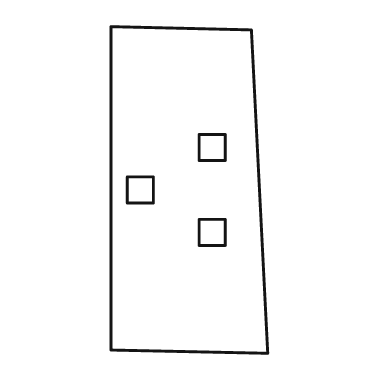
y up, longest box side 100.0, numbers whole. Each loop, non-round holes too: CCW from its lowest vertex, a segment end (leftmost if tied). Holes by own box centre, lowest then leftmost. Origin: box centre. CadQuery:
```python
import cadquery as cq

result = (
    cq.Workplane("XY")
    .moveTo(24.0, -50.0)
    .lineTo(19.0, 49.0)
    .lineTo(-24.0, 50.0)
    .lineTo(-24.0, -49.0)
    .close()
    .moveTo(3.0, -17.0)
    .lineTo(11.0, -17.0)
    .lineTo(11.0, -9.0)
    .lineTo(3.0, -9.0)
    .close()
    .moveTo(-19.0, -4.0)
    .lineTo(-11.0, -4.0)
    .lineTo(-11.0, 4.0)
    .lineTo(-19.0, 4.0)
    .close()
    .moveTo(3.0, 9.0)
    .lineTo(11.0, 9.0)
    .lineTo(11.0, 17.0)
    .lineTo(3.0, 17.0)
    .close()
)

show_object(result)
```